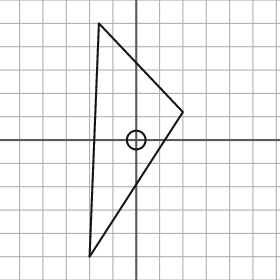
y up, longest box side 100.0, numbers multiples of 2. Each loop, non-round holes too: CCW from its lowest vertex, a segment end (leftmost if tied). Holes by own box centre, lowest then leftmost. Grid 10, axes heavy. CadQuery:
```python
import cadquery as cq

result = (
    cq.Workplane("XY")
    .moveTo(-20.0, -50.0)
    .lineTo(20.0, 12.0)
    .lineTo(-16.0, 50.0)
    .close()
    .moveTo(0.0, 0.0)
    .circle(4.0)
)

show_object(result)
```